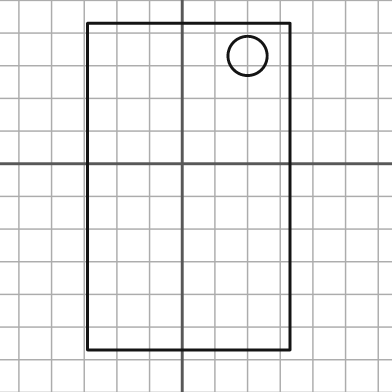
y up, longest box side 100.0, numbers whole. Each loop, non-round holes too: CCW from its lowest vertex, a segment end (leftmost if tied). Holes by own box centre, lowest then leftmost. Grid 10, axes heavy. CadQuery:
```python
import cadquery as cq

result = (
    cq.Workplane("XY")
    .moveTo(-29.0, -57.0)
    .lineTo(33.0, -57.0)
    .lineTo(33.0, 43.0)
    .lineTo(-29.0, 43.0)
    .close()
    .moveTo(20.0, 33.0)
    .circle(6.0)
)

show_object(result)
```